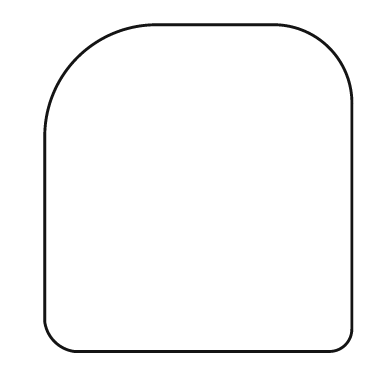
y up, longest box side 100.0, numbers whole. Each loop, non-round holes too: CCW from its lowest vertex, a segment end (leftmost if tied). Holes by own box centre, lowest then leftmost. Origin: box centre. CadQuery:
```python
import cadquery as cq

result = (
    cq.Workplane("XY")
    .moveTo(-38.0, -50.0)
    .lineTo(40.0, -50.0)
    .threePointArc((45.0, -48.0), (47.0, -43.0))
    .lineTo(47.0, 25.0)
    .threePointArc((40.0, 43.0), (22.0, 50.0))
    .lineTo(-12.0, 50.0)
    .threePointArc((-37.0, 40.0), (-47.0, 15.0))
    .lineTo(-47.0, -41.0)
    .threePointArc((-44.0, -47.0), (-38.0, -50.0))
    .close()
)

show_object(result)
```